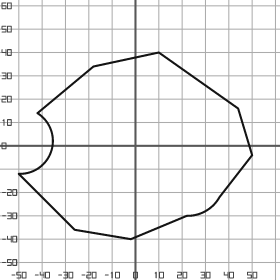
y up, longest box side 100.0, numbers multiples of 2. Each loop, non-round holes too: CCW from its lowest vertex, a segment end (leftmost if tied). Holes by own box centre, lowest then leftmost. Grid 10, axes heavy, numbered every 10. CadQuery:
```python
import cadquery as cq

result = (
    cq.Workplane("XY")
    .moveTo(-2.0, -40.0)
    .lineTo(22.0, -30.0)
    .threePointArc((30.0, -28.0), (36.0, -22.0))
    .lineTo(50.0, -4.0)
    .lineTo(44.0, 16.0)
    .lineTo(10.0, 40.0)
    .lineTo(-18.0, 34.0)
    .lineTo(-42.0, 14.0)
    .threePointArc((-36.0, -2.0), (-50.0, -12.0))
    .lineTo(-26.0, -36.0)
    .close()
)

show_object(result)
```